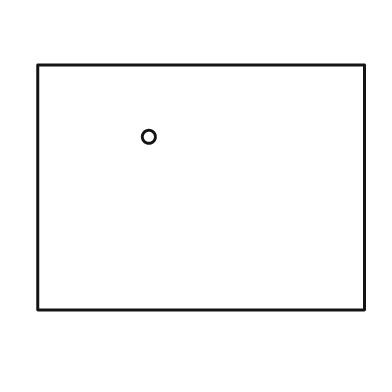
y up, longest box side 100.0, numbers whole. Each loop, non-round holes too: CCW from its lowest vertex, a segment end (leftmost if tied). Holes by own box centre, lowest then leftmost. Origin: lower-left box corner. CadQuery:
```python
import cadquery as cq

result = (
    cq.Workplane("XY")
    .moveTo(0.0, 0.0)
    .lineTo(100.0, 0.0)
    .lineTo(100.0, 75.0)
    .lineTo(0.0, 75.0)
    .close()
    .moveTo(34.0, 53.0)
    .circle(2.0)
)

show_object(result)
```